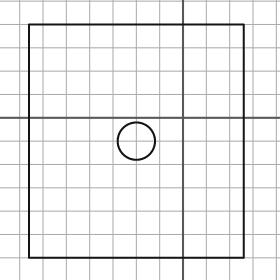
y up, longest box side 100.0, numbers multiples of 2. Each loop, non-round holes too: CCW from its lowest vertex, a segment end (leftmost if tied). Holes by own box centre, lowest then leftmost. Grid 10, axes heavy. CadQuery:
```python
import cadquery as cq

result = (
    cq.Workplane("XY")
    .moveTo(-66.0, -60.0)
    .lineTo(26.0, -60.0)
    .lineTo(26.0, 40.0)
    .lineTo(-66.0, 40.0)
    .close()
    .moveTo(-20.0, -10.0)
    .circle(8.0)
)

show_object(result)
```